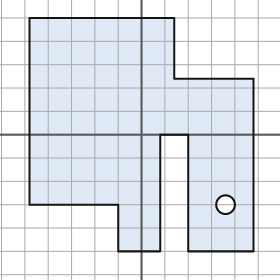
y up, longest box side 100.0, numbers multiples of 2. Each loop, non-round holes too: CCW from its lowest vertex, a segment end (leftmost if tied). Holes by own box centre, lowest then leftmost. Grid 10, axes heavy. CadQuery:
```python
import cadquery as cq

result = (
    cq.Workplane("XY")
    .moveTo(-10.0, -50.0)
    .lineTo(8.0, -50.0)
    .lineTo(8.0, 0.0)
    .lineTo(20.0, 0.0)
    .lineTo(20.0, -50.0)
    .lineTo(48.0, -50.0)
    .lineTo(48.0, 24.0)
    .lineTo(14.0, 24.0)
    .lineTo(14.0, 50.0)
    .lineTo(-48.0, 50.0)
    .lineTo(-48.0, -30.0)
    .lineTo(-10.0, -30.0)
    .close()
    .moveTo(36.0, -30.0)
    .circle(4.0)
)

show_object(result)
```